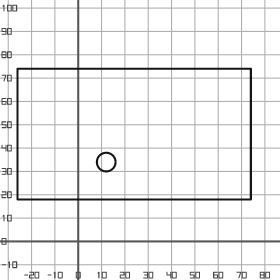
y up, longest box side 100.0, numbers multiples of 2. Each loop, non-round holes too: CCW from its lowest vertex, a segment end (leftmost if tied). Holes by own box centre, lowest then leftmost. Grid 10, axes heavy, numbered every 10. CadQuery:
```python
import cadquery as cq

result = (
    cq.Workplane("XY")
    .moveTo(-26.0, 18.0)
    .lineTo(74.0, 18.0)
    .lineTo(74.0, 74.0)
    .lineTo(-26.0, 74.0)
    .close()
    .moveTo(12.0, 34.0)
    .circle(4.0)
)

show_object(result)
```